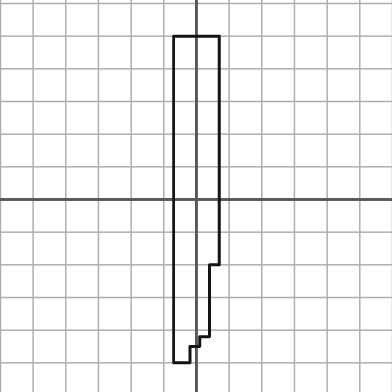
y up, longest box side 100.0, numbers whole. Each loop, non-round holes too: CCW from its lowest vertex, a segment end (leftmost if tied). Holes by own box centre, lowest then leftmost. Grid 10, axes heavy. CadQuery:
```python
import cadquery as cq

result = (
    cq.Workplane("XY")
    .moveTo(-7.0, -50.0)
    .lineTo(-2.0, -50.0)
    .lineTo(-2.0, -45.0)
    .lineTo(1.0, -45.0)
    .lineTo(1.0, -42.0)
    .lineTo(4.0, -42.0)
    .lineTo(4.0, -20.0)
    .lineTo(7.0, -20.0)
    .lineTo(7.0, 50.0)
    .lineTo(-7.0, 50.0)
    .close()
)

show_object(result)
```